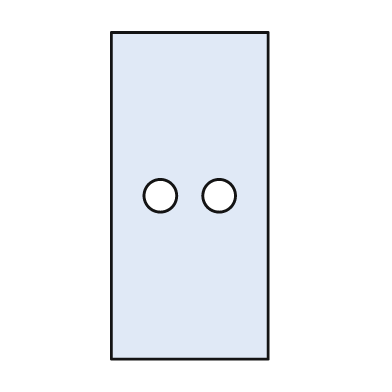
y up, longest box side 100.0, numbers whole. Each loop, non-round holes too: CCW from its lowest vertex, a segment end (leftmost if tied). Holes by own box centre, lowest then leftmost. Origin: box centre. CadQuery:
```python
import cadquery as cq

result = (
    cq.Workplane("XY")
    .moveTo(-24.0, -50.0)
    .lineTo(24.0, -50.0)
    .lineTo(24.0, 50.0)
    .lineTo(-24.0, 50.0)
    .close()
    .moveTo(-9.0, 0.0)
    .circle(5.0)
    .moveTo(9.0, 0.0)
    .circle(5.0)
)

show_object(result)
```